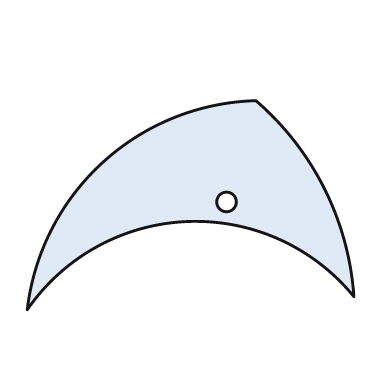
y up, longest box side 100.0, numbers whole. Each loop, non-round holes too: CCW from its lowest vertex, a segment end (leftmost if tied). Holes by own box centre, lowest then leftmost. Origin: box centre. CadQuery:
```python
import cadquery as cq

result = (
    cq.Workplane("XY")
    .moveTo(-50.0, -32.0)
    .threePointArc((-1.0, -5.0), (50.0, -28.0))
    .threePointArc((41.0, 5.0), (20.0, 32.0))
    .threePointArc((-27.0, 13.0), (-50.0, -32.0))
    .close()
    .moveTo(11.0, 1.0)
    .circle(3.0)
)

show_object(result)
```